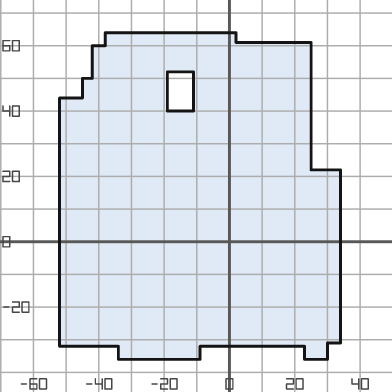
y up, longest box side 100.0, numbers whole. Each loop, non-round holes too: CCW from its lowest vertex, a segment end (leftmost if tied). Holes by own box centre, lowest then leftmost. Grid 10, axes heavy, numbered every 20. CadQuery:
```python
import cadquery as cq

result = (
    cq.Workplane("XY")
    .moveTo(-34.0, -36.0)
    .lineTo(-9.0, -36.0)
    .lineTo(-9.0, -32.0)
    .lineTo(23.0, -32.0)
    .lineTo(23.0, -36.0)
    .lineTo(30.0, -36.0)
    .lineTo(30.0, -31.0)
    .lineTo(34.0, -31.0)
    .lineTo(34.0, 22.0)
    .lineTo(25.0, 22.0)
    .lineTo(25.0, 61.0)
    .lineTo(2.0, 61.0)
    .lineTo(2.0, 64.0)
    .lineTo(-38.0, 64.0)
    .lineTo(-38.0, 60.0)
    .lineTo(-42.0, 60.0)
    .lineTo(-42.0, 50.0)
    .lineTo(-45.0, 50.0)
    .lineTo(-45.0, 44.0)
    .lineTo(-52.0, 44.0)
    .lineTo(-52.0, -32.0)
    .lineTo(-34.0, -32.0)
    .close()
    .moveTo(-19.0, 40.0)
    .lineTo(-11.0, 40.0)
    .lineTo(-11.0, 52.0)
    .lineTo(-19.0, 52.0)
    .close()
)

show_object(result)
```